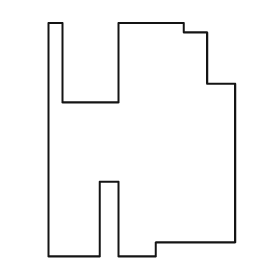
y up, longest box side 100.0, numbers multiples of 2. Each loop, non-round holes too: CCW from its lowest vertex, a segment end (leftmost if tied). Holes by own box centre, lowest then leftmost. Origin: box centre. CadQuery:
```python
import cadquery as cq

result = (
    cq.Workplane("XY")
    .moveTo(-40.0, -50.0)
    .lineTo(-18.0, -50.0)
    .lineTo(-18.0, -18.0)
    .lineTo(-10.0, -18.0)
    .lineTo(-10.0, -50.0)
    .lineTo(6.0, -50.0)
    .lineTo(6.0, -44.0)
    .lineTo(40.0, -44.0)
    .lineTo(40.0, 24.0)
    .lineTo(28.0, 24.0)
    .lineTo(28.0, 46.0)
    .lineTo(18.0, 46.0)
    .lineTo(18.0, 50.0)
    .lineTo(-10.0, 50.0)
    .lineTo(-10.0, 16.0)
    .lineTo(-34.0, 16.0)
    .lineTo(-34.0, 50.0)
    .lineTo(-40.0, 50.0)
    .close()
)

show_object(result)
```